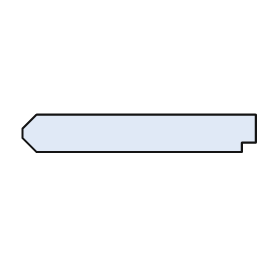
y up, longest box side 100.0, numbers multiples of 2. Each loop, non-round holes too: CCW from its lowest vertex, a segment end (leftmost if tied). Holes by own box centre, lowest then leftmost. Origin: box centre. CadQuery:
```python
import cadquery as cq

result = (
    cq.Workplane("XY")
    .moveTo(-44.0, -8.0)
    .lineTo(44.0, -8.0)
    .lineTo(44.0, -4.0)
    .lineTo(50.0, -4.0)
    .lineTo(50.0, 8.0)
    .lineTo(-44.0, 8.0)
    .lineTo(-50.0, 2.0)
    .lineTo(-50.0, -2.0)
    .close()
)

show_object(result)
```